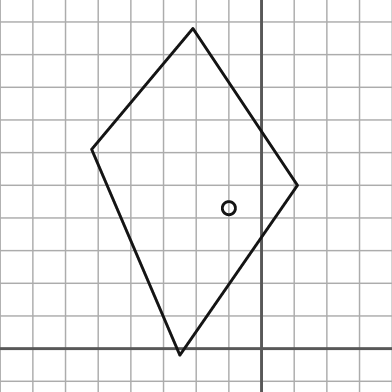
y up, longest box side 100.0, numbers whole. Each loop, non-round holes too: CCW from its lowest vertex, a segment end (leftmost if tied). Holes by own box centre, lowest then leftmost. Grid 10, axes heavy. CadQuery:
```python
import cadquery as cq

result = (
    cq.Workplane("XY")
    .moveTo(-25.0, -2.0)
    .lineTo(11.0, 50.0)
    .lineTo(-21.0, 98.0)
    .lineTo(-52.0, 61.0)
    .close()
    .moveTo(-10.0, 43.0)
    .circle(2.0)
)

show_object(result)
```